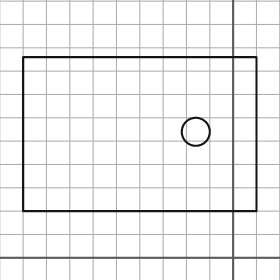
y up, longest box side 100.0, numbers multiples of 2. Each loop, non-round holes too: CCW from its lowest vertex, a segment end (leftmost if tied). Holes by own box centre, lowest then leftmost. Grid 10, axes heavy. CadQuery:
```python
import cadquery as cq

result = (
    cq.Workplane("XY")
    .moveTo(-90.0, 20.0)
    .lineTo(10.0, 20.0)
    .lineTo(10.0, 86.0)
    .lineTo(-90.0, 86.0)
    .close()
    .moveTo(-16.0, 54.0)
    .circle(6.0)
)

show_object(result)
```